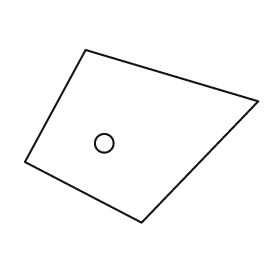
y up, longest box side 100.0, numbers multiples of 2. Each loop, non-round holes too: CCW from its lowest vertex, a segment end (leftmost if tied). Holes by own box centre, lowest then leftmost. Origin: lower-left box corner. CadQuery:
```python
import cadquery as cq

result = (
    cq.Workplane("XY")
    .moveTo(50.0, 0.0)
    .lineTo(100.0, 52.0)
    .lineTo(26.0, 74.0)
    .lineTo(0.0, 26.0)
    .close()
    .moveTo(34.0, 34.0)
    .circle(4.0)
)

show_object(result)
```